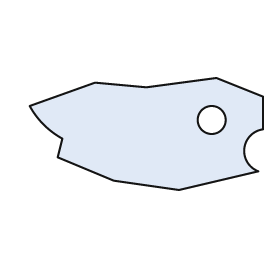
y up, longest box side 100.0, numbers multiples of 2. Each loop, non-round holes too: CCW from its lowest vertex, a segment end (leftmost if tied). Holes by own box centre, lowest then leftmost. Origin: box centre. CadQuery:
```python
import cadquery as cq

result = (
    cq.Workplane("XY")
    .moveTo(14.0, -24.0)
    .lineTo(48.0, -16.0)
    .threePointArc((42.0, -6.0), (50.0, 2.0))
    .lineTo(50.0, 16.0)
    .lineTo(30.0, 24.0)
    .lineTo(0.0, 20.0)
    .lineTo(-22.0, 22.0)
    .lineTo(-50.0, 12.0)
    .threePointArc((-44.0, 4.0), (-36.0, -2.0))
    .lineTo(-38.0, -10.0)
    .lineTo(-14.0, -20.0)
    .close()
    .moveTo(28.0, 6.0)
    .circle(6.0)
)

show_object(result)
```